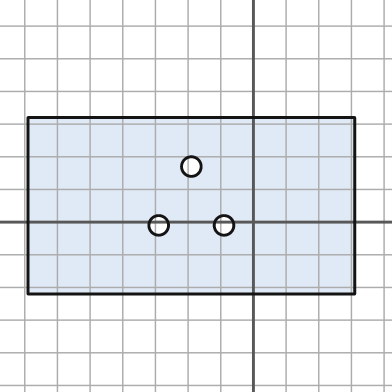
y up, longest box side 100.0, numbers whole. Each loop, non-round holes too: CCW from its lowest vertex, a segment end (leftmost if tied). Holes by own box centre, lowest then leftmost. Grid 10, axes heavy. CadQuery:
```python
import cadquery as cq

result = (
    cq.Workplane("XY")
    .moveTo(-69.0, -22.0)
    .lineTo(31.0, -22.0)
    .lineTo(31.0, 32.0)
    .lineTo(-69.0, 32.0)
    .close()
    .moveTo(-29.0, -1.0)
    .circle(3.0)
    .moveTo(-9.0, -1.0)
    .circle(3.0)
    .moveTo(-19.0, 17.0)
    .circle(3.0)
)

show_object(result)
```